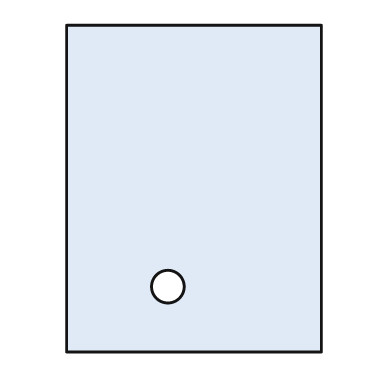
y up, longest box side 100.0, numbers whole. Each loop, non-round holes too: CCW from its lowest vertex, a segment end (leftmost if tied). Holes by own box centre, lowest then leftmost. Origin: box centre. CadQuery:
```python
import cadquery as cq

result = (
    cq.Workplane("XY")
    .moveTo(-39.0, -50.0)
    .lineTo(39.0, -50.0)
    .lineTo(39.0, 50.0)
    .lineTo(-39.0, 50.0)
    .close()
    .moveTo(-8.0, -30.0)
    .circle(5.0)
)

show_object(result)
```